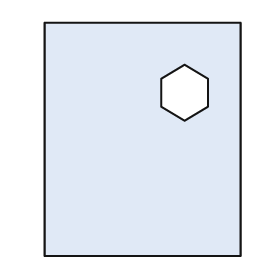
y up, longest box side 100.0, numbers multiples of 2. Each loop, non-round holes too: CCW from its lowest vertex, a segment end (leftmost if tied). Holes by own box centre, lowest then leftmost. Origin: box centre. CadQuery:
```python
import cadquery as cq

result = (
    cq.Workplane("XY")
    .moveTo(-42.0, -50.0)
    .lineTo(42.0, -50.0)
    .lineTo(42.0, 50.0)
    .lineTo(-42.0, 50.0)
    .close()
    .moveTo(18.0, 8.0)
    .lineTo(28.0, 14.0)
    .lineTo(28.0, 26.0)
    .lineTo(18.0, 32.0)
    .lineTo(8.0, 26.0)
    .lineTo(8.0, 14.0)
    .close()
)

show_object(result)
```